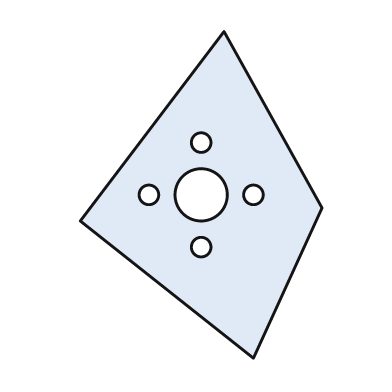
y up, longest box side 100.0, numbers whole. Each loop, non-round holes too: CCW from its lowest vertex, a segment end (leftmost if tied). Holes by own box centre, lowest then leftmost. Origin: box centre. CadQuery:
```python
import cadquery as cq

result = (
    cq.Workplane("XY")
    .moveTo(16.0, -50.0)
    .lineTo(37.0, -4.0)
    .lineTo(7.0, 50.0)
    .lineTo(-37.0, -8.0)
    .close()
    .moveTo(0.0, -16.0)
    .circle(3.0)
    .moveTo(-16.0, 0.0)
    .circle(3.0)
    .moveTo(0.0, 0.0)
    .circle(8.0)
    .moveTo(16.0, 0.0)
    .circle(3.0)
    .moveTo(0.0, 16.0)
    .circle(3.0)
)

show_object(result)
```